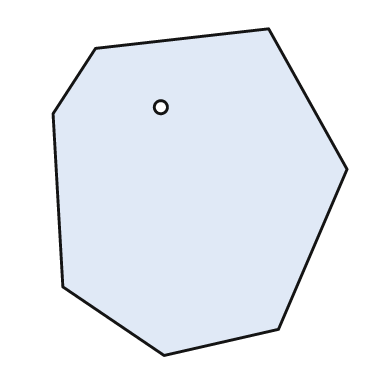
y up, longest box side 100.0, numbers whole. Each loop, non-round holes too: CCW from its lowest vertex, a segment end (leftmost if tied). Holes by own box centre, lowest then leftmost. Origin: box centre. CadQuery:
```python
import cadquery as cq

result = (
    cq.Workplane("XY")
    .moveTo(-11.0, -50.0)
    .lineTo(24.0, -42.0)
    .lineTo(45.0, 7.0)
    .lineTo(21.0, 50.0)
    .lineTo(-32.0, 44.0)
    .lineTo(-45.0, 24.0)
    .lineTo(-42.0, -29.0)
    .close()
    .moveTo(-12.0, 26.0)
    .circle(2.0)
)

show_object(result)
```